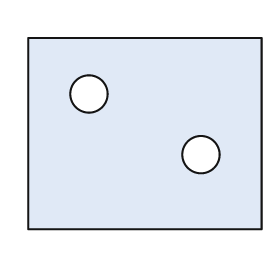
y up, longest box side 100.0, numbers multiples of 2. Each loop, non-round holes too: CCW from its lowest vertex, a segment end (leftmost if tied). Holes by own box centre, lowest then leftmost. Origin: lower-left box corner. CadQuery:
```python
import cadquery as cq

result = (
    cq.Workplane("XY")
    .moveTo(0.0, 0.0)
    .lineTo(100.0, 0.0)
    .lineTo(100.0, 82.0)
    .lineTo(0.0, 82.0)
    .close()
    .moveTo(74.0, 32.0)
    .circle(8.0)
    .moveTo(26.0, 58.0)
    .circle(8.0)
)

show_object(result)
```